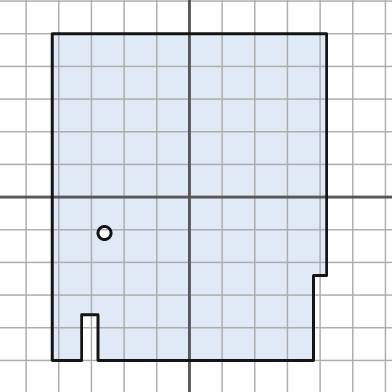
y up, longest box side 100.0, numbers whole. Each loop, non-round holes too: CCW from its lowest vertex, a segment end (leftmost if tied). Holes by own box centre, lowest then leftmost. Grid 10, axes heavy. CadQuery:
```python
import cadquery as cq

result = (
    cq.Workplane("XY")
    .moveTo(-42.0, -50.0)
    .lineTo(-33.0, -50.0)
    .lineTo(-33.0, -36.0)
    .lineTo(-28.0, -36.0)
    .lineTo(-28.0, -50.0)
    .lineTo(38.0, -50.0)
    .lineTo(38.0, -24.0)
    .lineTo(42.0, -24.0)
    .lineTo(42.0, 50.0)
    .lineTo(-42.0, 50.0)
    .close()
    .moveTo(-26.0, -11.0)
    .circle(2.0)
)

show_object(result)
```